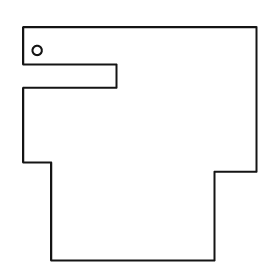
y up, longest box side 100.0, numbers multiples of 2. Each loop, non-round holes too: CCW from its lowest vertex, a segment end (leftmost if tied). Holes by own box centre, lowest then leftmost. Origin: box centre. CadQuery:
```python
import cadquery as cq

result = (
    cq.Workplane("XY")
    .moveTo(-38.0, -50.0)
    .lineTo(32.0, -50.0)
    .lineTo(32.0, -12.0)
    .lineTo(50.0, -12.0)
    .lineTo(50.0, 50.0)
    .lineTo(-50.0, 50.0)
    .lineTo(-50.0, 34.0)
    .lineTo(-10.0, 34.0)
    .lineTo(-10.0, 24.0)
    .lineTo(-50.0, 24.0)
    .lineTo(-50.0, -8.0)
    .lineTo(-38.0, -8.0)
    .close()
    .moveTo(-44.0, 40.0)
    .circle(2.0)
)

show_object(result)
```